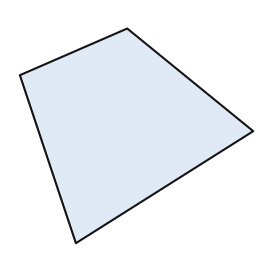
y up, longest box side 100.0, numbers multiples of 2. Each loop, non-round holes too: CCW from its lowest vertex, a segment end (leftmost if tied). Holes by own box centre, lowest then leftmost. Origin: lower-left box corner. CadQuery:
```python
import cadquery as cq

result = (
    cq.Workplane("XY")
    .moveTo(24.0, 0.0)
    .lineTo(100.0, 48.0)
    .lineTo(46.0, 92.0)
    .lineTo(0.0, 72.0)
    .close()
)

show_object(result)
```